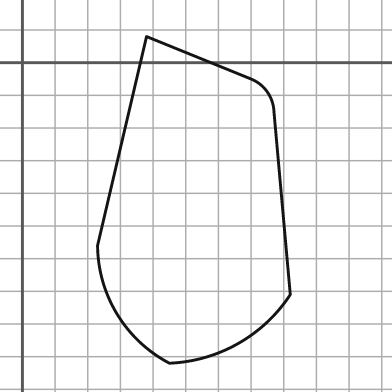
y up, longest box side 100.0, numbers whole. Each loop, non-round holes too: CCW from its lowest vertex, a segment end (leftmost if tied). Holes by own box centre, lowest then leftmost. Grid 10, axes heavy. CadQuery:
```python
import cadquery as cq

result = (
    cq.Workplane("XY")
    .moveTo(45.0, -92.0)
    .threePointArc((66.0, -86.0), (82.0, -71.0))
    .lineTo(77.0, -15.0)
    .threePointArc((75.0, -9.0), (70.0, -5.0))
    .lineTo(38.0, 8.0)
    .lineTo(23.0, -56.0)
    .threePointArc((29.0, -77.0), (45.0, -92.0))
    .close()
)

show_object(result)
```